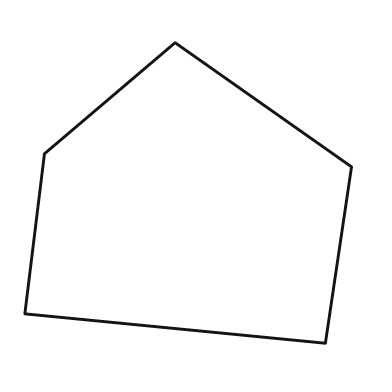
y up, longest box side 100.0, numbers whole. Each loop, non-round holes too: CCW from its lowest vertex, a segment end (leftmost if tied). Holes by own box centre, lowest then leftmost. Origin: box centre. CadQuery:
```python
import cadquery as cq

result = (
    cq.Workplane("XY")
    .moveTo(42.0, -46.0)
    .lineTo(50.0, 8.0)
    .lineTo(-4.0, 46.0)
    .lineTo(-44.0, 12.0)
    .lineTo(-50.0, -37.0)
    .close()
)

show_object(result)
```